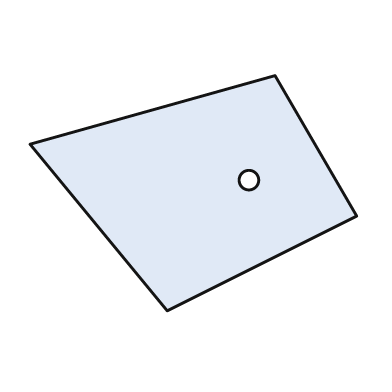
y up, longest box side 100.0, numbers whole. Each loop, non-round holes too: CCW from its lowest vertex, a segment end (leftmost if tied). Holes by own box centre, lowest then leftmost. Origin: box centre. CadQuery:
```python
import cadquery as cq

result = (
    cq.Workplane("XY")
    .moveTo(-8.0, -36.0)
    .lineTo(50.0, -7.0)
    .lineTo(25.0, 36.0)
    .lineTo(-50.0, 15.0)
    .close()
    .moveTo(17.0, 4.0)
    .circle(3.0)
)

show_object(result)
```